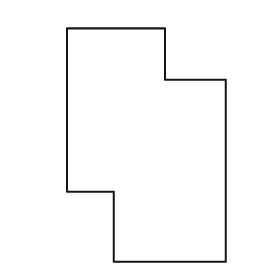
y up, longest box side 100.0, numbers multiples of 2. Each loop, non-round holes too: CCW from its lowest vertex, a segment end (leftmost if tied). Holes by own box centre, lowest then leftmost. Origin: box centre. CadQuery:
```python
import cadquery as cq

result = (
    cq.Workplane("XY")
    .moveTo(-14.0, -50.0)
    .lineTo(34.0, -50.0)
    .lineTo(34.0, 28.0)
    .lineTo(8.0, 28.0)
    .lineTo(8.0, 50.0)
    .lineTo(-34.0, 50.0)
    .lineTo(-34.0, -20.0)
    .lineTo(-14.0, -20.0)
    .close()
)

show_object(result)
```